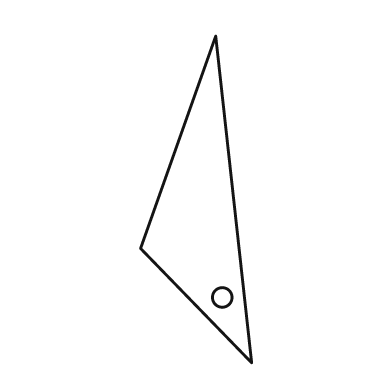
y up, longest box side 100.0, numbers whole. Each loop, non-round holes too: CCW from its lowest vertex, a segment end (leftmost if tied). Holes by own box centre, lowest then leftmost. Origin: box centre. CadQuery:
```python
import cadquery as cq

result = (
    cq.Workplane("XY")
    .moveTo(17.0, -50.0)
    .lineTo(6.0, 50.0)
    .lineTo(-17.0, -15.0)
    .close()
    .moveTo(8.0, -30.0)
    .circle(3.0)
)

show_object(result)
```